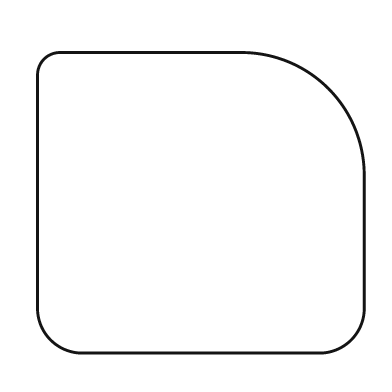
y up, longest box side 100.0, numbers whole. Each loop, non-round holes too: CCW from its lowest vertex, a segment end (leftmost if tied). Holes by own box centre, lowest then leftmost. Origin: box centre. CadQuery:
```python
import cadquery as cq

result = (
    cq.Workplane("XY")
    .moveTo(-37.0, -46.0)
    .lineTo(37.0, -46.0)
    .threePointArc((46.0, -42.0), (50.0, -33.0))
    .lineTo(50.0, 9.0)
    .threePointArc((39.0, 35.0), (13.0, 46.0))
    .lineTo(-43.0, 46.0)
    .threePointArc((-48.0, 44.0), (-50.0, 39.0))
    .lineTo(-50.0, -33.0)
    .threePointArc((-46.0, -42.0), (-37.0, -46.0))
    .close()
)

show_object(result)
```